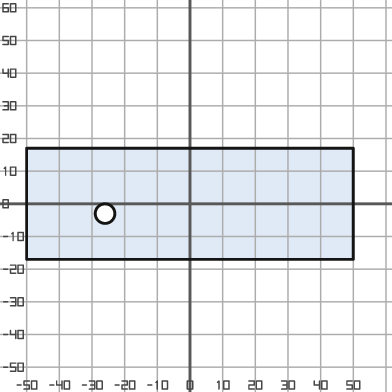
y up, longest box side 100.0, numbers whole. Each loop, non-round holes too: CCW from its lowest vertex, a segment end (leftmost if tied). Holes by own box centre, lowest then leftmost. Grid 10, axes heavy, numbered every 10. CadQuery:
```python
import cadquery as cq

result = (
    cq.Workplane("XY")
    .moveTo(-50.0, -17.0)
    .lineTo(50.0, -17.0)
    .lineTo(50.0, 17.0)
    .lineTo(-50.0, 17.0)
    .close()
    .moveTo(-26.0, -3.0)
    .circle(3.0)
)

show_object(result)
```